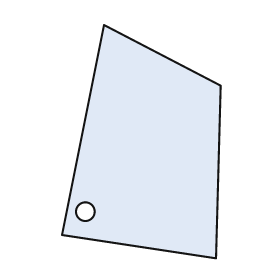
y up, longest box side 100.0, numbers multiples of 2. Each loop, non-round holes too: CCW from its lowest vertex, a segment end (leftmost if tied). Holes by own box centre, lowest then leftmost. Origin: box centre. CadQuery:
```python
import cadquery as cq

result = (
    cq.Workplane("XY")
    .moveTo(32.0, -50.0)
    .lineTo(34.0, 24.0)
    .lineTo(-16.0, 50.0)
    .lineTo(-34.0, -40.0)
    .close()
    .moveTo(-24.0, -30.0)
    .circle(4.0)
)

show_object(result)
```